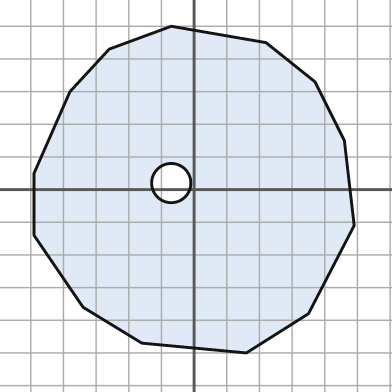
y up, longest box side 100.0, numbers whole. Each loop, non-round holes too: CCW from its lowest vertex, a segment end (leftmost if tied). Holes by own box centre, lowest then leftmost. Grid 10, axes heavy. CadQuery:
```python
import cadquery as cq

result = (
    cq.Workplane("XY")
    .moveTo(16.0, -50.0)
    .lineTo(35.0, -38.0)
    .lineTo(49.0, -11.0)
    .lineTo(46.0, 15.0)
    .lineTo(37.0, 33.0)
    .lineTo(22.0, 45.0)
    .lineTo(-7.0, 50.0)
    .lineTo(-26.0, 43.0)
    .lineTo(-38.0, 30.0)
    .lineTo(-49.0, 5.0)
    .lineTo(-49.0, -14.0)
    .lineTo(-34.0, -36.0)
    .lineTo(-16.0, -47.0)
    .close()
    .moveTo(-7.0, 2.0)
    .circle(6.0)
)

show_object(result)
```